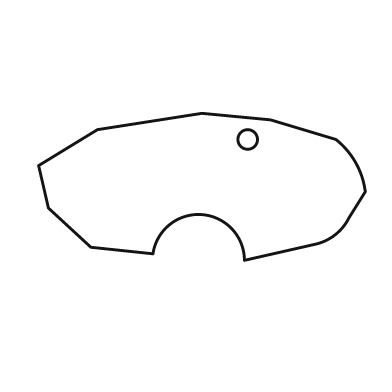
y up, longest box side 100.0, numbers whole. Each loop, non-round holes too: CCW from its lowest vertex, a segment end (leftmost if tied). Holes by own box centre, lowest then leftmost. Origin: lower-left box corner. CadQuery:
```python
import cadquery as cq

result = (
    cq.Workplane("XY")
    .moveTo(63.0, 0.0)
    .lineTo(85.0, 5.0)
    .threePointArc((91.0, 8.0), (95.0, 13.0))
    .lineTo(100.0, 21.0)
    .threePointArc((97.0, 30.0), (91.0, 37.0))
    .lineTo(71.0, 43.0)
    .lineTo(50.0, 45.0)
    .lineTo(18.0, 40.0)
    .lineTo(0.0, 29.0)
    .lineTo(3.0, 16.0)
    .lineTo(16.0, 4.0)
    .lineTo(35.0, 2.0)
    .threePointArc((50.0, 14.0), (63.0, 0.0))
    .close()
    .moveTo(64.0, 37.0)
    .circle(3.0)
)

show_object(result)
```